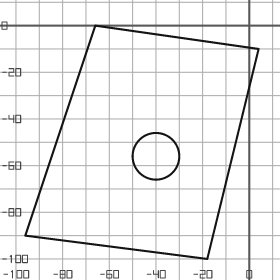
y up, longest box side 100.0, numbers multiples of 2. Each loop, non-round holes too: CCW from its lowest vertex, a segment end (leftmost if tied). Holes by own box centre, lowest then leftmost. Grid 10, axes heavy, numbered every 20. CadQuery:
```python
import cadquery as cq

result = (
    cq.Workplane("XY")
    .moveTo(-18.0, -100.0)
    .lineTo(4.0, -10.0)
    .lineTo(-66.0, 0.0)
    .lineTo(-96.0, -90.0)
    .close()
    .moveTo(-40.0, -56.0)
    .circle(10.0)
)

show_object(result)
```